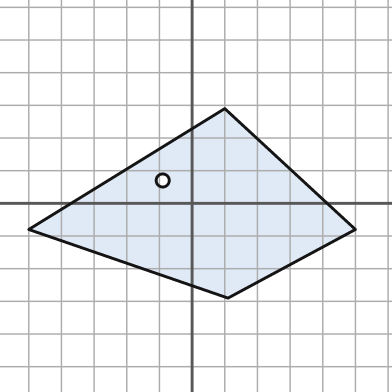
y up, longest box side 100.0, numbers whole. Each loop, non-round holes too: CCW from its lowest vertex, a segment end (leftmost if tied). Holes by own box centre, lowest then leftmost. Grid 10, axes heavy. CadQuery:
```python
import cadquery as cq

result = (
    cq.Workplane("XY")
    .moveTo(11.0, -29.0)
    .lineTo(50.0, -8.0)
    .lineTo(10.0, 29.0)
    .lineTo(-50.0, -8.0)
    .close()
    .moveTo(-9.0, 7.0)
    .circle(2.0)
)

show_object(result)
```